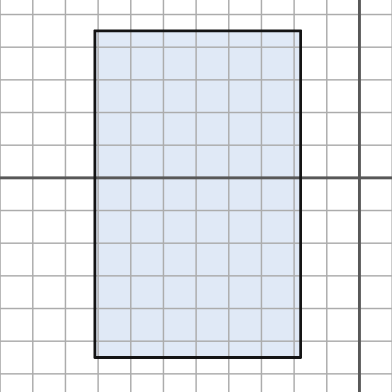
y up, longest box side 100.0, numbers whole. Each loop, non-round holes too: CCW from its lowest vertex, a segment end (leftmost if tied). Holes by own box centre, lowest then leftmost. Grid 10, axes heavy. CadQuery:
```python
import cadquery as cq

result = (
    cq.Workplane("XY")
    .moveTo(-81.0, -55.0)
    .lineTo(-18.0, -55.0)
    .lineTo(-18.0, 45.0)
    .lineTo(-81.0, 45.0)
    .close()
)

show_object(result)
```